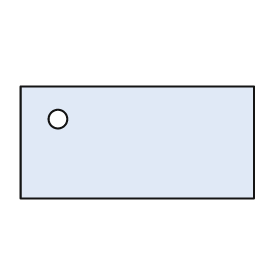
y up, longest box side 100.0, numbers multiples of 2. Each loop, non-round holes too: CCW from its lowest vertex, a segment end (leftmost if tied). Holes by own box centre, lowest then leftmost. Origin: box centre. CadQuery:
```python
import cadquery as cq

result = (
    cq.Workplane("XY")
    .moveTo(-50.0, -24.0)
    .lineTo(50.0, -24.0)
    .lineTo(50.0, 24.0)
    .lineTo(-50.0, 24.0)
    .close()
    .moveTo(-34.0, 10.0)
    .circle(4.0)
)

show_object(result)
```